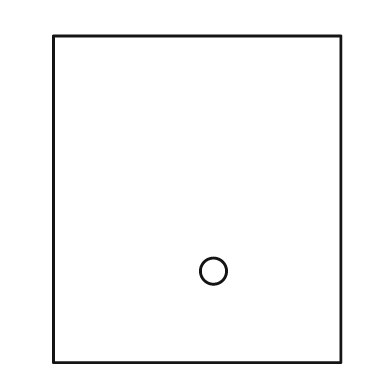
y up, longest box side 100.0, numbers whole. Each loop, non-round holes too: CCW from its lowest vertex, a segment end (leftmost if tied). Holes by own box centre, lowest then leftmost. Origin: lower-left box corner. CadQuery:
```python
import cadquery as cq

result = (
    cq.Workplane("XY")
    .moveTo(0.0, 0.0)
    .lineTo(88.0, 0.0)
    .lineTo(88.0, 100.0)
    .lineTo(0.0, 100.0)
    .close()
    .moveTo(49.0, 28.0)
    .circle(4.0)
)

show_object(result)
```